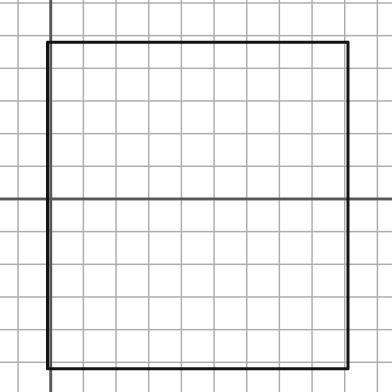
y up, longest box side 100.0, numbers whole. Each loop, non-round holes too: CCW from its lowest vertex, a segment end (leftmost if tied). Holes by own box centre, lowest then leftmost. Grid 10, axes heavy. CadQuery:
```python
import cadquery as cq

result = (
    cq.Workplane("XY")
    .moveTo(-1.0, -52.0)
    .lineTo(91.0, -52.0)
    .lineTo(91.0, 48.0)
    .lineTo(-1.0, 48.0)
    .close()
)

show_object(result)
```